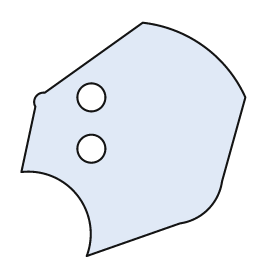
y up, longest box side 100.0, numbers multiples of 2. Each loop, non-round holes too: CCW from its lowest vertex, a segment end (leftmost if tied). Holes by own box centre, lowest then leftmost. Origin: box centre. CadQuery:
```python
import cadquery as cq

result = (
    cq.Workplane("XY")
    .moveTo(-20.0, -50.0)
    .lineTo(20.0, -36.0)
    .threePointArc((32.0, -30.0), (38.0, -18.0))
    .lineTo(48.0, 18.0)
    .threePointArc((30.0, 40.0), (4.0, 50.0))
    .lineTo(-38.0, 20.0)
    .threePointArc((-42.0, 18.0), (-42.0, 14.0))
    .lineTo(-48.0, -14.0)
    .threePointArc((-24.0, -24.0), (-20.0, -50.0))
    .close()
    .moveTo(-18.0, -4.0)
    .circle(6.0)
    .moveTo(-18.0, 18.0)
    .circle(6.0)
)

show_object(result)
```